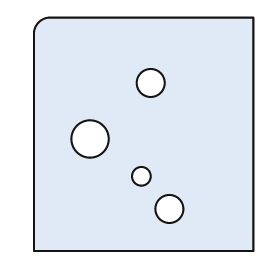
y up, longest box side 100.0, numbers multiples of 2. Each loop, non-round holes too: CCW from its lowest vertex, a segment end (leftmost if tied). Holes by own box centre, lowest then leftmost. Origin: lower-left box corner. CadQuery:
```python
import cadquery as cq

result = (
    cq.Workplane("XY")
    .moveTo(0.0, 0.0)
    .lineTo(94.0, 0.0)
    .lineTo(94.0, 100.0)
    .lineTo(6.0, 100.0)
    .threePointArc((2.0, 98.0), (0.0, 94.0))
    .close()
    .moveTo(58.0, 18.0)
    .circle(6.0)
    .moveTo(46.0, 32.0)
    .circle(4.0)
    .moveTo(24.0, 48.0)
    .circle(8.0)
    .moveTo(50.0, 72.0)
    .circle(6.0)
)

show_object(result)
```